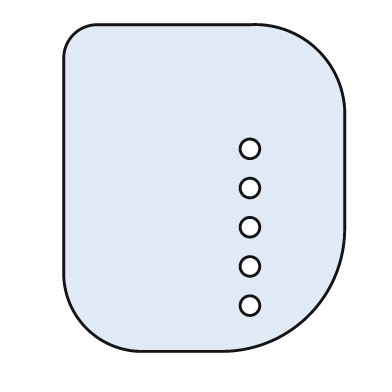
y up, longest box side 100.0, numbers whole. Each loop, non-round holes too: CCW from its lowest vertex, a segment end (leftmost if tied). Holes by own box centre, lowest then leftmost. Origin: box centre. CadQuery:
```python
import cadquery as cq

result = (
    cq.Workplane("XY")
    .moveTo(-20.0, -50.0)
    .lineTo(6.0, -50.0)
    .threePointArc((32.0, -39.0), (43.0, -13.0))
    .lineTo(43.0, 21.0)
    .threePointArc((35.0, 42.0), (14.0, 50.0))
    .lineTo(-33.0, 50.0)
    .threePointArc((-40.0, 47.0), (-43.0, 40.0))
    .lineTo(-43.0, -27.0)
    .threePointArc((-36.0, -43.0), (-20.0, -50.0))
    .close()
    .moveTo(14.0, -36.0)
    .circle(3.0)
    .moveTo(14.0, -24.0)
    .circle(3.0)
    .moveTo(14.0, -12.0)
    .circle(3.0)
    .moveTo(14.0, 0.0)
    .circle(3.0)
    .moveTo(14.0, 12.0)
    .circle(3.0)
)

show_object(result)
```